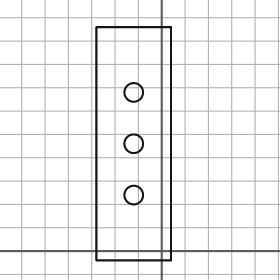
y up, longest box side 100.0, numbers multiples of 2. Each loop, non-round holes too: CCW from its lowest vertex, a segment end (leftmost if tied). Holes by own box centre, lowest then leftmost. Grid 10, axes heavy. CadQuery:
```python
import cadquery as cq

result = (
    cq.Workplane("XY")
    .moveTo(-28.0, -4.0)
    .lineTo(4.0, -4.0)
    .lineTo(4.0, 96.0)
    .lineTo(-28.0, 96.0)
    .close()
    .moveTo(-12.0, 24.0)
    .circle(4.0)
    .moveTo(-12.0, 46.0)
    .circle(4.0)
    .moveTo(-12.0, 68.0)
    .circle(4.0)
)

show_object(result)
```